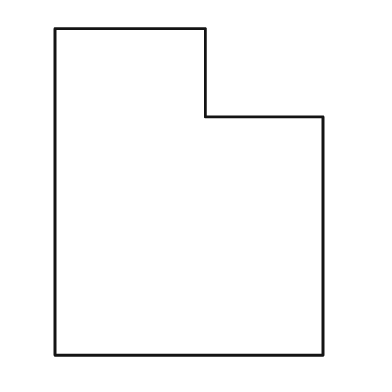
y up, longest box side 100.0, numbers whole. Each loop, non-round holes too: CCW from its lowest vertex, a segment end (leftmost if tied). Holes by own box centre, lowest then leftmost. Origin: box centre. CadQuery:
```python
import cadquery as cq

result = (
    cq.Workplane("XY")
    .moveTo(-41.0, -50.0)
    .lineTo(41.0, -50.0)
    .lineTo(41.0, 23.0)
    .lineTo(5.0, 23.0)
    .lineTo(5.0, 50.0)
    .lineTo(-41.0, 50.0)
    .close()
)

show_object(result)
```